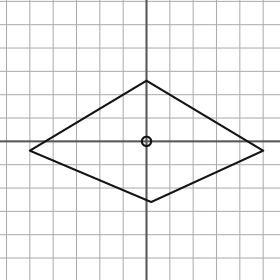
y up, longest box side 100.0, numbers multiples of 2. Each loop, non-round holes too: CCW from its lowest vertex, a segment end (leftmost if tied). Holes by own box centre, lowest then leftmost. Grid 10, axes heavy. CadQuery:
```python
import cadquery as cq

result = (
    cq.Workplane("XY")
    .moveTo(2.0, -26.0)
    .lineTo(50.0, -4.0)
    .lineTo(0.0, 26.0)
    .lineTo(-50.0, -4.0)
    .close()
    .moveTo(0.0, 0.0)
    .circle(2.0)
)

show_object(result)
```